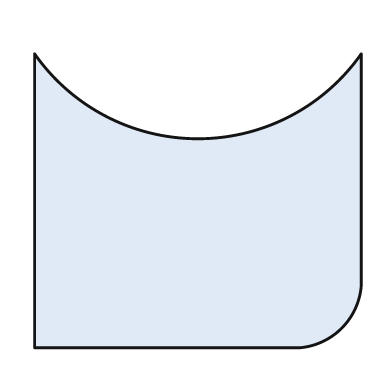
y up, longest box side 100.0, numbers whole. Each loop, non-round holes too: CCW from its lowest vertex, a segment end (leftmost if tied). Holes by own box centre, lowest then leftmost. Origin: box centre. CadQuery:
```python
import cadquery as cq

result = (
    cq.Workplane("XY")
    .moveTo(-50.0, -45.0)
    .lineTo(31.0, -45.0)
    .threePointArc((44.0, -39.0), (50.0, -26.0))
    .lineTo(50.0, 45.0)
    .threePointArc((0.0, 19.0), (-50.0, 45.0))
    .close()
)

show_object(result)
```